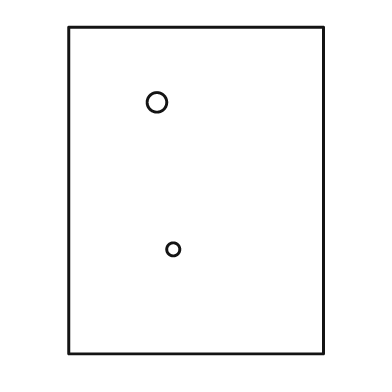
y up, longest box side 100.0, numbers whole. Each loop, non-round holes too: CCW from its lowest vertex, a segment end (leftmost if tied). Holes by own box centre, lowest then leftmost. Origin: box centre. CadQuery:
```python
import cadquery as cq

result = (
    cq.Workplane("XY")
    .moveTo(-39.0, -50.0)
    .lineTo(39.0, -50.0)
    .lineTo(39.0, 50.0)
    .lineTo(-39.0, 50.0)
    .close()
    .moveTo(-7.0, -18.0)
    .circle(2.0)
    .moveTo(-12.0, 27.0)
    .circle(3.0)
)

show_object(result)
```